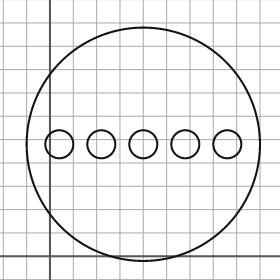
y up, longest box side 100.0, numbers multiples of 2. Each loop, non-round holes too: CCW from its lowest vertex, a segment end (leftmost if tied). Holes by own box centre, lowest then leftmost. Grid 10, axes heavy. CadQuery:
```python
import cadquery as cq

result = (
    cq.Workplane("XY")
    .moveTo(40.0, 48.0)
    .circle(50.0)
    .moveTo(4.0, 48.0)
    .circle(6.0)
    .moveTo(22.0, 48.0)
    .circle(6.0)
    .moveTo(40.0, 48.0)
    .circle(6.0)
    .moveTo(58.0, 48.0)
    .circle(6.0)
    .moveTo(76.0, 48.0)
    .circle(6.0)
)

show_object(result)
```